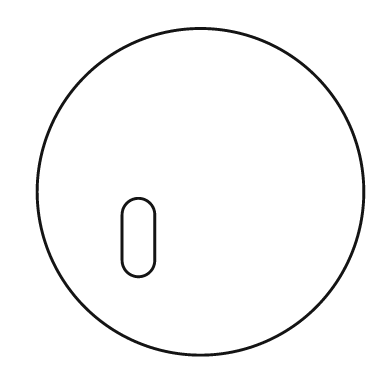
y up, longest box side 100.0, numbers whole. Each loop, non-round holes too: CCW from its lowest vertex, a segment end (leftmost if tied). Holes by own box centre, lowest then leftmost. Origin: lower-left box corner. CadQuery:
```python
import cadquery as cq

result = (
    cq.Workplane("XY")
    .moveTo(50.0, 50.0)
    .circle(50.0)
    .moveTo(26.0, 29.0)
    .threePointArc((31.0, 24.0), (36.0, 29.0))
    .lineTo(36.0, 43.0)
    .threePointArc((31.0, 48.0), (26.0, 43.0))
    .close()
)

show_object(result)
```